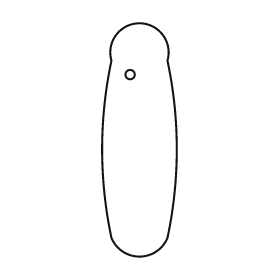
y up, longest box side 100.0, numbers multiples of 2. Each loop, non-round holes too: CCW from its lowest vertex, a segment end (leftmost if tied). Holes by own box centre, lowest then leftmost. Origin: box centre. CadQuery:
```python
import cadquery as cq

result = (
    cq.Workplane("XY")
    .moveTo(-12.0, -42.0)
    .threePointArc((0.0, -50.0), (12.0, -42.0))
    .threePointArc((16.0, -4.0), (12.0, 34.0))
    .threePointArc((0.0, 50.0), (-12.0, 34.0))
    .threePointArc((-16.0, -4.0), (-12.0, -42.0))
    .close()
    .moveTo(-4.0, 28.0)
    .circle(2.0)
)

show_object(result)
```